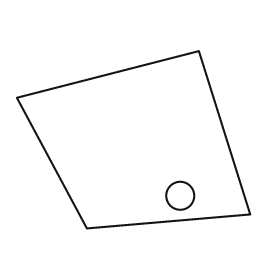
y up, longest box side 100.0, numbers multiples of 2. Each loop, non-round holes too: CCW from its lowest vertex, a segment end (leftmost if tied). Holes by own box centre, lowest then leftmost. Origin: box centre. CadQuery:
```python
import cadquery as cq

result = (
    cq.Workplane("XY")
    .moveTo(-20.0, -38.0)
    .lineTo(50.0, -32.0)
    .lineTo(28.0, 38.0)
    .lineTo(-50.0, 18.0)
    .close()
    .moveTo(20.0, -24.0)
    .circle(6.0)
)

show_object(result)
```